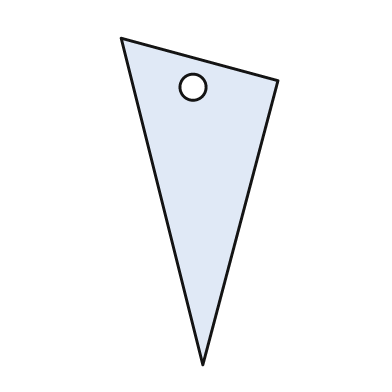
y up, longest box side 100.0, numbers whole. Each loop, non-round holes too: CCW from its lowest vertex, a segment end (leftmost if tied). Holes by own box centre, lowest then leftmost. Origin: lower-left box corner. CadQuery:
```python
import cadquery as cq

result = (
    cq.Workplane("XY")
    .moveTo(25.0, 0.0)
    .lineTo(48.0, 87.0)
    .lineTo(0.0, 100.0)
    .close()
    .moveTo(22.0, 85.0)
    .circle(4.0)
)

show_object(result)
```